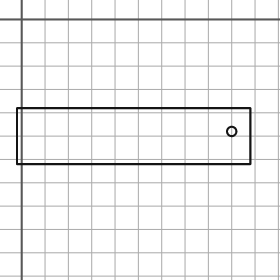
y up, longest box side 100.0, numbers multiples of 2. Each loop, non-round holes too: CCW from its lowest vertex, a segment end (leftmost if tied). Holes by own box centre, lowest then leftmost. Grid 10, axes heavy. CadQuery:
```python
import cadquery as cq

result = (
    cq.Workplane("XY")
    .moveTo(-2.0, -62.0)
    .lineTo(98.0, -62.0)
    .lineTo(98.0, -38.0)
    .lineTo(-2.0, -38.0)
    .close()
    .moveTo(90.0, -48.0)
    .circle(2.0)
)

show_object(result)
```